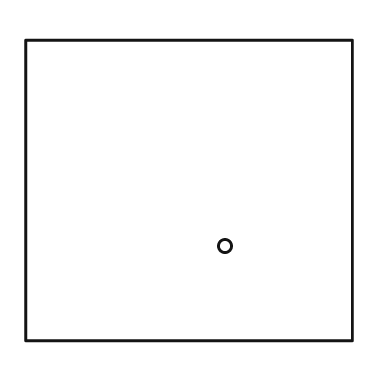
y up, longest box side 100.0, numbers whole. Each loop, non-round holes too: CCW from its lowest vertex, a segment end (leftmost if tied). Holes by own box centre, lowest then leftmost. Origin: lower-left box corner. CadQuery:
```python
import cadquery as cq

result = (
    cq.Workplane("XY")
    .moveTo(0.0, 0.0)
    .lineTo(100.0, 0.0)
    .lineTo(100.0, 92.0)
    .lineTo(0.0, 92.0)
    .close()
    .moveTo(61.0, 29.0)
    .circle(2.0)
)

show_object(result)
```